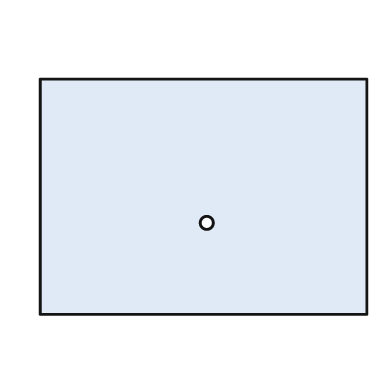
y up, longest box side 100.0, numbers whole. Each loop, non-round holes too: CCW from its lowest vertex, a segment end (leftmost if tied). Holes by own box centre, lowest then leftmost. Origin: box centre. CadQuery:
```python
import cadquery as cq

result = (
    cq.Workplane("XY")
    .moveTo(-50.0, -36.0)
    .lineTo(50.0, -36.0)
    .lineTo(50.0, 36.0)
    .lineTo(-50.0, 36.0)
    .close()
    .moveTo(1.0, -8.0)
    .circle(2.0)
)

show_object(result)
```